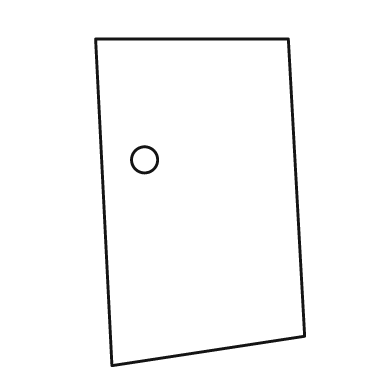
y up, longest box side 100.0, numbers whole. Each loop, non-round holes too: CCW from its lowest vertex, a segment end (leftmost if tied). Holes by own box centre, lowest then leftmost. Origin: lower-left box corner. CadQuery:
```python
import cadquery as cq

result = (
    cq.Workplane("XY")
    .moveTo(5.0, 0.0)
    .lineTo(64.0, 9.0)
    .lineTo(59.0, 100.0)
    .lineTo(0.0, 100.0)
    .close()
    .moveTo(15.0, 63.0)
    .circle(4.0)
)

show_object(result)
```